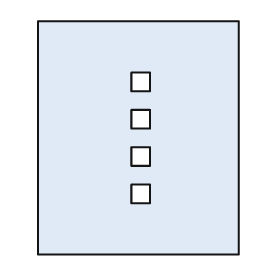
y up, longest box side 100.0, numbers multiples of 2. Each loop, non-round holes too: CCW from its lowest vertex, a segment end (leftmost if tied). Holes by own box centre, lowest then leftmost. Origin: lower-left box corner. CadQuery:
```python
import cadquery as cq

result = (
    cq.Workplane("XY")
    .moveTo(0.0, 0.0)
    .lineTo(86.0, 0.0)
    .lineTo(86.0, 100.0)
    .lineTo(0.0, 100.0)
    .close()
    .moveTo(40.0, 22.0)
    .lineTo(48.0, 22.0)
    .lineTo(48.0, 30.0)
    .lineTo(40.0, 30.0)
    .close()
    .moveTo(40.0, 38.0)
    .lineTo(48.0, 38.0)
    .lineTo(48.0, 46.0)
    .lineTo(40.0, 46.0)
    .close()
    .moveTo(40.0, 54.0)
    .lineTo(48.0, 54.0)
    .lineTo(48.0, 62.0)
    .lineTo(40.0, 62.0)
    .close()
    .moveTo(40.0, 70.0)
    .lineTo(48.0, 70.0)
    .lineTo(48.0, 78.0)
    .lineTo(40.0, 78.0)
    .close()
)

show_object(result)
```